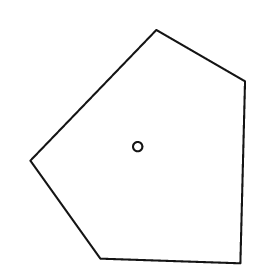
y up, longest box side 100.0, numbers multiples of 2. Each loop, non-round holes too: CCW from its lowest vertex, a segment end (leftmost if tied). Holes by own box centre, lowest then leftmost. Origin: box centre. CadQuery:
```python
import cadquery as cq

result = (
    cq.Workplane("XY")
    .moveTo(44.0, -50.0)
    .lineTo(46.0, 28.0)
    .lineTo(8.0, 50.0)
    .lineTo(-46.0, -6.0)
    .lineTo(-16.0, -48.0)
    .close()
    .moveTo(0.0, 0.0)
    .circle(2.0)
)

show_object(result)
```